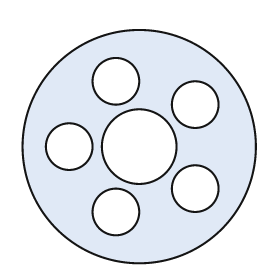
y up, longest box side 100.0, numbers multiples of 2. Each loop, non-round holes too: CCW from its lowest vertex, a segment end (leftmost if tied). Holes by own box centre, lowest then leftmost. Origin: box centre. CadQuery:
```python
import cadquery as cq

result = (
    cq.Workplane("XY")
    .moveTo(0.0, 0.0)
    .circle(50.0)
    .moveTo(-10.0, -28.0)
    .circle(10.0)
    .moveTo(24.0, -18.0)
    .circle(10.0)
    .moveTo(-30.0, 0.0)
    .circle(10.0)
    .moveTo(0.0, 0.0)
    .circle(16.0)
    .moveTo(24.0, 18.0)
    .circle(10.0)
    .moveTo(-10.0, 28.0)
    .circle(10.0)
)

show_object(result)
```